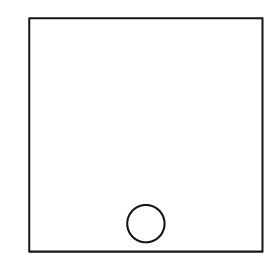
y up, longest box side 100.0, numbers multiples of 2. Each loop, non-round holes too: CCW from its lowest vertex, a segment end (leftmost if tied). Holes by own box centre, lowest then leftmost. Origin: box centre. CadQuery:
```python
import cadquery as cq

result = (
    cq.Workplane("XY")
    .moveTo(-50.0, -50.0)
    .lineTo(50.0, -50.0)
    .lineTo(50.0, 50.0)
    .lineTo(-50.0, 50.0)
    .close()
    .moveTo(0.0, -38.0)
    .circle(8.0)
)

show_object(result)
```